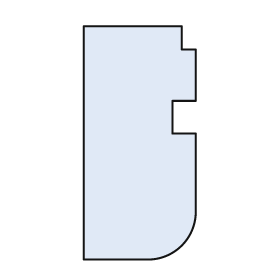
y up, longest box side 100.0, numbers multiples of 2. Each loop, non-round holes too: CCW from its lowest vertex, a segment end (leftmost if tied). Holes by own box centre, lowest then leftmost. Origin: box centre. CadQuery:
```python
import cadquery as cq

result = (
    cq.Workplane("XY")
    .moveTo(-24.0, -50.0)
    .lineTo(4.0, -50.0)
    .threePointArc((18.0, -44.0), (24.0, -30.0))
    .lineTo(24.0, 4.0)
    .lineTo(14.0, 4.0)
    .lineTo(14.0, 18.0)
    .lineTo(24.0, 18.0)
    .lineTo(24.0, 40.0)
    .lineTo(18.0, 40.0)
    .lineTo(18.0, 50.0)
    .lineTo(-24.0, 50.0)
    .close()
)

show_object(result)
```